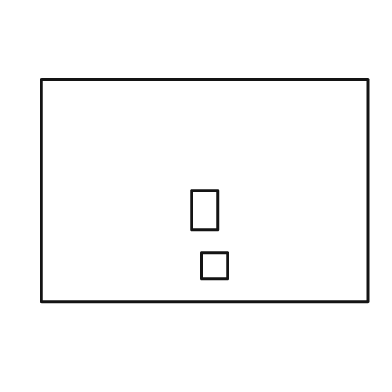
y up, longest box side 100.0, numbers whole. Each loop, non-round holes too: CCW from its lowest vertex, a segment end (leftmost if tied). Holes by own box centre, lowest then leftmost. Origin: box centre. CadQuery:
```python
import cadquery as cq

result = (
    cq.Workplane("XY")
    .moveTo(-50.0, -34.0)
    .lineTo(50.0, -34.0)
    .lineTo(50.0, 34.0)
    .lineTo(-50.0, 34.0)
    .close()
    .moveTo(-1.0, -27.0)
    .lineTo(7.0, -27.0)
    .lineTo(7.0, -19.0)
    .lineTo(-1.0, -19.0)
    .close()
    .moveTo(-4.0, -12.0)
    .lineTo(4.0, -12.0)
    .lineTo(4.0, 0.0)
    .lineTo(-4.0, 0.0)
    .close()
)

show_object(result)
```